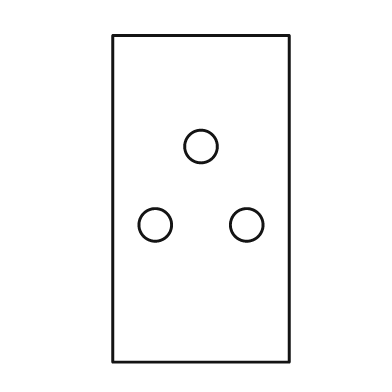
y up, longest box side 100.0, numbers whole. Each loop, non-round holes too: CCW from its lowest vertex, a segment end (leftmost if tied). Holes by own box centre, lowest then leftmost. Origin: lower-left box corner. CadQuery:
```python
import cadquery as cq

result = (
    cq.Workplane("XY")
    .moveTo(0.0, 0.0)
    .lineTo(54.0, 0.0)
    .lineTo(54.0, 100.0)
    .lineTo(0.0, 100.0)
    .close()
    .moveTo(13.0, 42.0)
    .circle(5.0)
    .moveTo(41.0, 42.0)
    .circle(5.0)
    .moveTo(27.0, 66.0)
    .circle(5.0)
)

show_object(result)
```